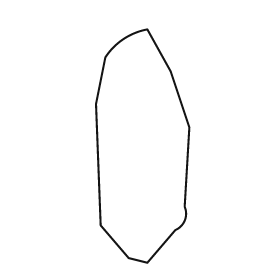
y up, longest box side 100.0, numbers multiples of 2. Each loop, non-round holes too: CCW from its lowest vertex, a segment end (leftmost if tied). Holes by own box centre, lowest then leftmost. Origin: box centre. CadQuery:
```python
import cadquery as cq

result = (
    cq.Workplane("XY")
    .moveTo(2.0, -50.0)
    .lineTo(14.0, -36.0)
    .threePointArc((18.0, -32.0), (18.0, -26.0))
    .lineTo(20.0, 8.0)
    .lineTo(12.0, 32.0)
    .lineTo(2.0, 50.0)
    .threePointArc((-8.0, 46.0), (-16.0, 38.0))
    .lineTo(-20.0, 18.0)
    .lineTo(-18.0, -34.0)
    .lineTo(-6.0, -48.0)
    .close()
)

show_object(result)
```